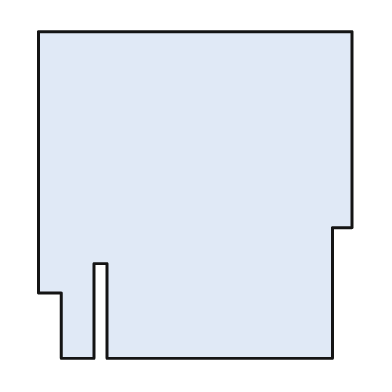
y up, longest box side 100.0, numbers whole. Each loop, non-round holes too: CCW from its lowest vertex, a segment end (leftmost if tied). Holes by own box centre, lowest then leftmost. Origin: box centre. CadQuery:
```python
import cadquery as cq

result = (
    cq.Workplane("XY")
    .moveTo(-41.0, -50.0)
    .lineTo(-31.0, -50.0)
    .lineTo(-31.0, -21.0)
    .lineTo(-27.0, -21.0)
    .lineTo(-27.0, -50.0)
    .lineTo(42.0, -50.0)
    .lineTo(42.0, -10.0)
    .lineTo(48.0, -10.0)
    .lineTo(48.0, 50.0)
    .lineTo(-48.0, 50.0)
    .lineTo(-48.0, -30.0)
    .lineTo(-41.0, -30.0)
    .close()
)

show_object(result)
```